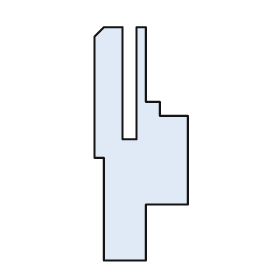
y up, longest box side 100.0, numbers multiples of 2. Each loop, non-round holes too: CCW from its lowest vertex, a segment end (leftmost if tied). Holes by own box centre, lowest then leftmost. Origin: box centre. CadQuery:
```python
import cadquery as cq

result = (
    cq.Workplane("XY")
    .moveTo(-16.0, -50.0)
    .lineTo(2.0, -50.0)
    .lineTo(2.0, -26.0)
    .lineTo(20.0, -26.0)
    .lineTo(20.0, 12.0)
    .lineTo(8.0, 12.0)
    .lineTo(8.0, 18.0)
    .lineTo(2.0, 18.0)
    .lineTo(2.0, 50.0)
    .lineTo(-2.0, 50.0)
    .lineTo(-2.0, 2.0)
    .lineTo(-8.0, 2.0)
    .lineTo(-8.0, 50.0)
    .lineTo(-16.0, 50.0)
    .lineTo(-20.0, 46.0)
    .lineTo(-20.0, -6.0)
    .lineTo(-16.0, -6.0)
    .close()
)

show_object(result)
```